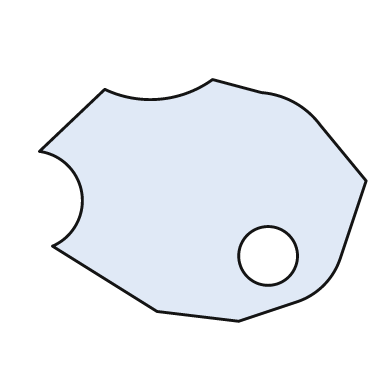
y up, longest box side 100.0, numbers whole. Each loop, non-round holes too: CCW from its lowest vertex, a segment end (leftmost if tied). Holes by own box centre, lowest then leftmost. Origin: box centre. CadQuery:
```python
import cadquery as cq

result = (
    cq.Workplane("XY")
    .moveTo(11.0, -37.0)
    .lineTo(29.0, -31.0)
    .threePointArc((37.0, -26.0), (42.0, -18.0))
    .lineTo(50.0, 6.0)
    .lineTo(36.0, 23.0)
    .threePointArc((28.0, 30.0), (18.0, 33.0))
    .lineTo(3.0, 37.0)
    .threePointArc((-13.0, 31.0), (-30.0, 34.0))
    .lineTo(-50.0, 15.0)
    .threePointArc((-37.0, 2.0), (-46.0, -14.0))
    .lineTo(-14.0, -34.0)
    .close()
    .moveTo(20.0, -17.0)
    .circle(9.0)
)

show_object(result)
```